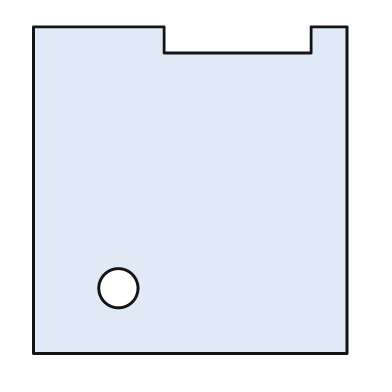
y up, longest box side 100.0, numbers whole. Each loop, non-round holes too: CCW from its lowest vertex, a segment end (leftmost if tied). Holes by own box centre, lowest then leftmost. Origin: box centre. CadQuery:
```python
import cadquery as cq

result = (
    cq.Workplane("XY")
    .moveTo(-48.0, -50.0)
    .lineTo(48.0, -50.0)
    .lineTo(48.0, 50.0)
    .lineTo(37.0, 50.0)
    .lineTo(37.0, 42.0)
    .lineTo(-8.0, 42.0)
    .lineTo(-8.0, 50.0)
    .lineTo(-48.0, 50.0)
    .close()
    .moveTo(-22.0, -30.0)
    .circle(6.0)
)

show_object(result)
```